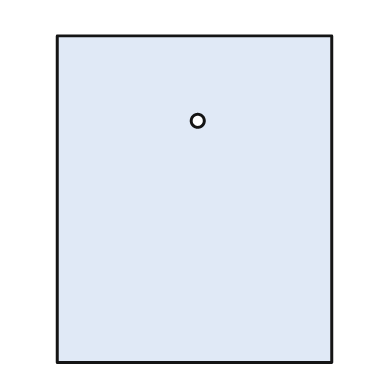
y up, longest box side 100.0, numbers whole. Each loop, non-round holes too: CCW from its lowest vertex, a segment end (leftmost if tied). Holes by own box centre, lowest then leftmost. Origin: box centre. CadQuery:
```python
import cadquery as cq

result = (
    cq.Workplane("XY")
    .moveTo(-42.0, -50.0)
    .lineTo(42.0, -50.0)
    .lineTo(42.0, 50.0)
    .lineTo(-42.0, 50.0)
    .close()
    .moveTo(1.0, 24.0)
    .circle(2.0)
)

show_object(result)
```